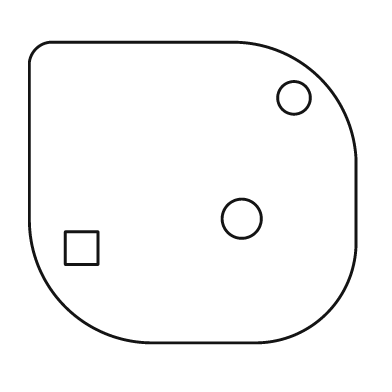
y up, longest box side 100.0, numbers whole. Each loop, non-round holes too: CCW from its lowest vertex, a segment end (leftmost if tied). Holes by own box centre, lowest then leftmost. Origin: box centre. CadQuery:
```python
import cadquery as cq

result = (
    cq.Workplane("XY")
    .moveTo(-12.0, -46.0)
    .lineTo(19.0, -46.0)
    .threePointArc((41.0, -37.0), (50.0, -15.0))
    .lineTo(50.0, 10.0)
    .threePointArc((39.0, 35.0), (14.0, 46.0))
    .lineTo(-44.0, 46.0)
    .threePointArc((-48.0, 44.0), (-50.0, 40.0))
    .lineTo(-50.0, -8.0)
    .threePointArc((-39.0, -35.0), (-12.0, -46.0))
    .close()
    .moveTo(-39.0, -22.0)
    .lineTo(-29.0, -22.0)
    .lineTo(-29.0, -12.0)
    .lineTo(-39.0, -12.0)
    .close()
    .moveTo(15.0, -8.0)
    .circle(6.0)
    .moveTo(31.0, 29.0)
    .circle(5.0)
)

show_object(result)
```